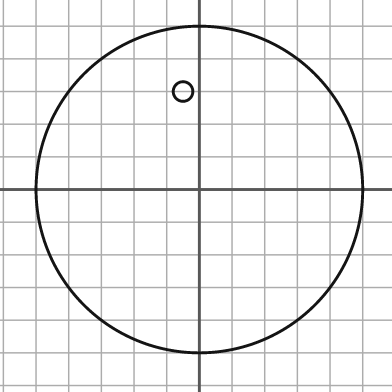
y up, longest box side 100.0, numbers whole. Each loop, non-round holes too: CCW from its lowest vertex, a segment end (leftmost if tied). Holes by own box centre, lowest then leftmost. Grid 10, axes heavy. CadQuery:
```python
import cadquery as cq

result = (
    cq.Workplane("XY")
    .moveTo(0.0, 0.0)
    .circle(50.0)
    .moveTo(-5.0, 30.0)
    .circle(3.0)
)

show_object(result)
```